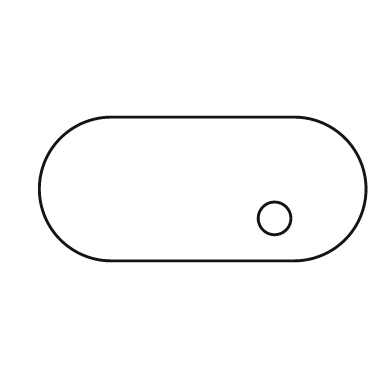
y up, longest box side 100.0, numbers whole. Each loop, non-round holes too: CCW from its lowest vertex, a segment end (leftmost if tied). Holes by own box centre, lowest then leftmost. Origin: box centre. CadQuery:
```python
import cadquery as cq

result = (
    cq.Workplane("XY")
    .moveTo(-28.0, -22.0)
    .lineTo(28.0, -22.0)
    .threePointArc((50.0, 0.0), (28.0, 22.0))
    .lineTo(-28.0, 22.0)
    .threePointArc((-50.0, 0.0), (-28.0, -22.0))
    .close()
    .moveTo(22.0, -9.0)
    .circle(5.0)
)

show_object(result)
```